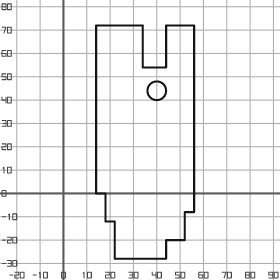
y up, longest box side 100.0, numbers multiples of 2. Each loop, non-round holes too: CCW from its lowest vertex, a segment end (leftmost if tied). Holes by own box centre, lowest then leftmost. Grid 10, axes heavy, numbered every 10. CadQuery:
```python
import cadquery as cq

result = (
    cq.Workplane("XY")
    .moveTo(22.0, -28.0)
    .lineTo(44.0, -28.0)
    .lineTo(44.0, -20.0)
    .lineTo(52.0, -20.0)
    .lineTo(52.0, -8.0)
    .lineTo(56.0, -8.0)
    .lineTo(56.0, 72.0)
    .lineTo(44.0, 72.0)
    .lineTo(44.0, 54.0)
    .lineTo(34.0, 54.0)
    .lineTo(34.0, 72.0)
    .lineTo(14.0, 72.0)
    .lineTo(14.0, 0.0)
    .lineTo(18.0, 0.0)
    .lineTo(18.0, -12.0)
    .lineTo(22.0, -12.0)
    .close()
    .moveTo(40.0, 44.0)
    .circle(4.0)
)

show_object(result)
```